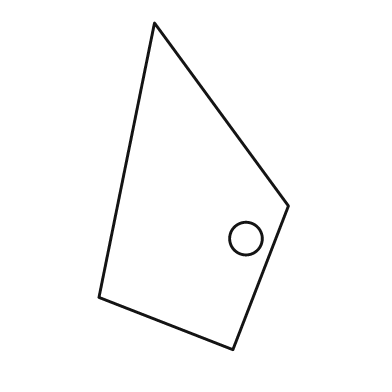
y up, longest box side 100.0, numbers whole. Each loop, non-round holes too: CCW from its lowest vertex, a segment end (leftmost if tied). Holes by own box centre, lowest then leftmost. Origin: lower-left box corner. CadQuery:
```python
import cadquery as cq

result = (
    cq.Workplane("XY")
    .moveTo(41.0, 0.0)
    .lineTo(58.0, 44.0)
    .lineTo(17.0, 100.0)
    .lineTo(0.0, 16.0)
    .close()
    .moveTo(45.0, 34.0)
    .circle(5.0)
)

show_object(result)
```